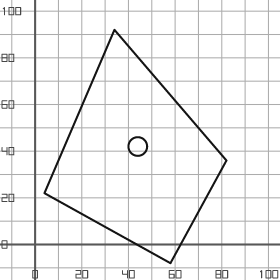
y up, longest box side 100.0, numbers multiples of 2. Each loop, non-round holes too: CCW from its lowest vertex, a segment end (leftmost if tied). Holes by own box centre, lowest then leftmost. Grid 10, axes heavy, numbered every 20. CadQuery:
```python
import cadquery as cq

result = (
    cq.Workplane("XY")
    .moveTo(58.0, -8.0)
    .lineTo(82.0, 36.0)
    .lineTo(34.0, 92.0)
    .lineTo(4.0, 22.0)
    .close()
    .moveTo(44.0, 42.0)
    .circle(4.0)
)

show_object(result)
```